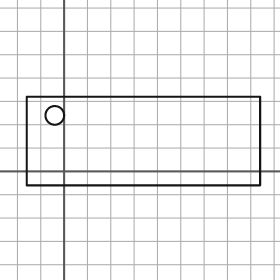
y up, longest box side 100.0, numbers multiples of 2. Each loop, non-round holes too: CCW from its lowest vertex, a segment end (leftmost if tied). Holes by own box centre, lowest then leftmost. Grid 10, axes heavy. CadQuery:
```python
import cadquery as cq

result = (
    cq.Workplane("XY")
    .moveTo(-16.0, -6.0)
    .lineTo(84.0, -6.0)
    .lineTo(84.0, 32.0)
    .lineTo(-16.0, 32.0)
    .close()
    .moveTo(-4.0, 24.0)
    .circle(4.0)
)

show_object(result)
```